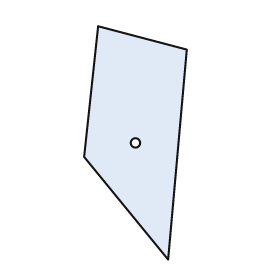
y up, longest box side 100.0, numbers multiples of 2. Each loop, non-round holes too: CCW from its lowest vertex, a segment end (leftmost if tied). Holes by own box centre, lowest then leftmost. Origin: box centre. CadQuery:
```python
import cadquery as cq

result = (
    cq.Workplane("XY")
    .moveTo(14.0, -50.0)
    .lineTo(22.0, 40.0)
    .lineTo(-16.0, 50.0)
    .lineTo(-22.0, -6.0)
    .close()
    .moveTo(0.0, 0.0)
    .circle(2.0)
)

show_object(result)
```